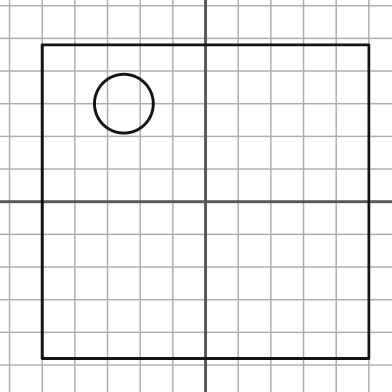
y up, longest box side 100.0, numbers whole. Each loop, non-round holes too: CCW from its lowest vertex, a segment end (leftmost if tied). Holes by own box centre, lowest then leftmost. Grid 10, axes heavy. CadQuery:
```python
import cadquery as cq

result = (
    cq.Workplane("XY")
    .moveTo(-50.0, -48.0)
    .lineTo(50.0, -48.0)
    .lineTo(50.0, 48.0)
    .lineTo(-50.0, 48.0)
    .close()
    .moveTo(-25.0, 30.0)
    .circle(9.0)
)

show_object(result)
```